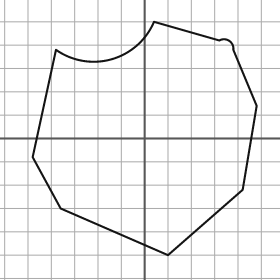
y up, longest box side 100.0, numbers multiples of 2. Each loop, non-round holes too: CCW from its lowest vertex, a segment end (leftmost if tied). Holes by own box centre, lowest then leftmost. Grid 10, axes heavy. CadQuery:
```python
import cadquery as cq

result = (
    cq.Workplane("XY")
    .moveTo(10.0, -50.0)
    .lineTo(42.0, -22.0)
    .lineTo(48.0, 14.0)
    .lineTo(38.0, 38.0)
    .threePointArc((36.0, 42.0), (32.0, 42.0))
    .lineTo(4.0, 50.0)
    .threePointArc((-14.0, 34.0), (-38.0, 38.0))
    .lineTo(-48.0, -8.0)
    .lineTo(-36.0, -30.0)
    .close()
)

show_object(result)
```